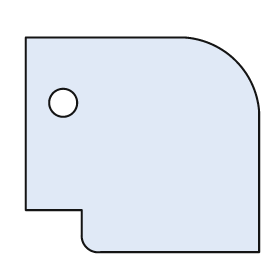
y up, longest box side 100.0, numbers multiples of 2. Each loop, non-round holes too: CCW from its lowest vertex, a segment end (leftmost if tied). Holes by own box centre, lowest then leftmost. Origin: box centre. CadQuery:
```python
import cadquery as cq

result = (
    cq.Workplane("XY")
    .moveTo(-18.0, -46.0)
    .lineTo(50.0, -46.0)
    .lineTo(50.0, 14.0)
    .threePointArc((40.0, 36.0), (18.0, 46.0))
    .lineTo(-50.0, 46.0)
    .lineTo(-50.0, -28.0)
    .lineTo(-26.0, -28.0)
    .lineTo(-26.0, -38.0)
    .threePointArc((-24.0, -44.0), (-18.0, -46.0))
    .close()
    .moveTo(-34.0, 18.0)
    .circle(6.0)
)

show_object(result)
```